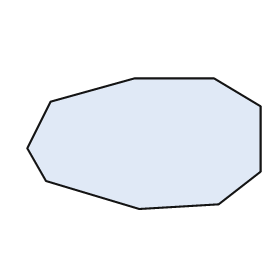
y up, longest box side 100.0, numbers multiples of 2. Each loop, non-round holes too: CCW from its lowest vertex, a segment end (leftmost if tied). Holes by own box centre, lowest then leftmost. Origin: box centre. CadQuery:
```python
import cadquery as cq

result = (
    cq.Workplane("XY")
    .moveTo(-2.0, -28.0)
    .lineTo(32.0, -26.0)
    .lineTo(50.0, -12.0)
    .lineTo(50.0, 16.0)
    .lineTo(30.0, 28.0)
    .lineTo(-4.0, 28.0)
    .lineTo(-40.0, 18.0)
    .lineTo(-50.0, -2.0)
    .lineTo(-42.0, -16.0)
    .close()
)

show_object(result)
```